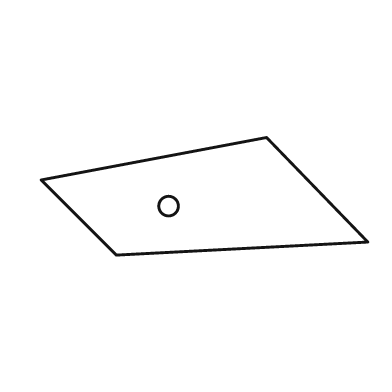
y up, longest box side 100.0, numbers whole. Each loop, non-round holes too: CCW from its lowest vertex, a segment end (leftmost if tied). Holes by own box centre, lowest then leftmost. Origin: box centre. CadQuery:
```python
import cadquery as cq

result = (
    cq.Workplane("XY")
    .moveTo(-27.0, -18.0)
    .lineTo(50.0, -14.0)
    .lineTo(19.0, 18.0)
    .lineTo(-50.0, 5.0)
    .close()
    .moveTo(-11.0, -3.0)
    .circle(3.0)
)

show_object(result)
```